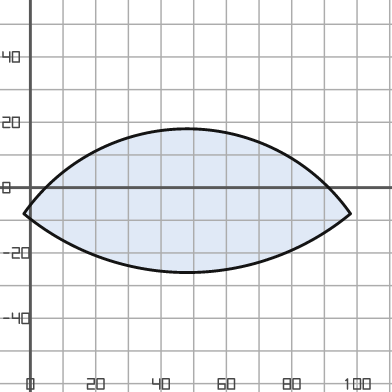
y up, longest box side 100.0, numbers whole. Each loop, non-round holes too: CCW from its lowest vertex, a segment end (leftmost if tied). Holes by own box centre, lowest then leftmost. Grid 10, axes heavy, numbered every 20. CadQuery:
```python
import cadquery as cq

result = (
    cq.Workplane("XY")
    .moveTo(-2.0, -8.0)
    .threePointArc((48.0, -26.0), (98.0, -8.0))
    .threePointArc((48.0, 18.0), (-2.0, -8.0))
    .close()
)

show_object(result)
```